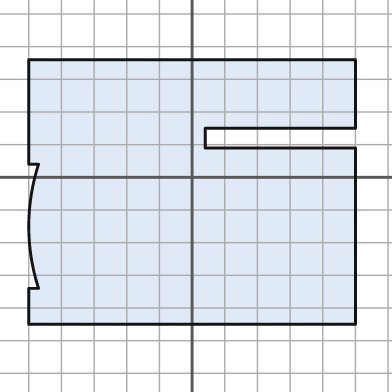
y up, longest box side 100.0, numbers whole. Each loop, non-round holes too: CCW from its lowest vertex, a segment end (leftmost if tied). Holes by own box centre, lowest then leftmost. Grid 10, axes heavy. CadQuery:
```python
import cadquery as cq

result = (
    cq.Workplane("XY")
    .moveTo(-50.0, -45.0)
    .lineTo(50.0, -45.0)
    .lineTo(50.0, 9.0)
    .lineTo(4.0, 9.0)
    .lineTo(4.0, 15.0)
    .lineTo(50.0, 15.0)
    .lineTo(50.0, 36.0)
    .lineTo(-50.0, 36.0)
    .lineTo(-50.0, 4.0)
    .lineTo(-47.0, 4.0)
    .threePointArc((-50.0, -15.0), (-47.0, -34.0))
    .lineTo(-50.0, -34.0)
    .close()
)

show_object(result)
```